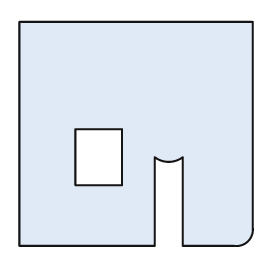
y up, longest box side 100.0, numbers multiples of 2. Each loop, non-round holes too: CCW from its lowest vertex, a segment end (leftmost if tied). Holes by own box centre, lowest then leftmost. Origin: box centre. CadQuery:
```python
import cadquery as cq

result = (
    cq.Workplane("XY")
    .moveTo(-50.0, -48.0)
    .lineTo(8.0, -48.0)
    .lineTo(8.0, -10.0)
    .threePointArc((14.0, -12.0), (20.0, -10.0))
    .lineTo(20.0, -48.0)
    .lineTo(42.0, -48.0)
    .threePointArc((48.0, -46.0), (50.0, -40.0))
    .lineTo(50.0, 48.0)
    .lineTo(-50.0, 48.0)
    .close()
    .moveTo(-26.0, -22.0)
    .lineTo(-6.0, -22.0)
    .lineTo(-6.0, 2.0)
    .lineTo(-26.0, 2.0)
    .close()
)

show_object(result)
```